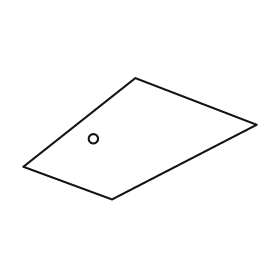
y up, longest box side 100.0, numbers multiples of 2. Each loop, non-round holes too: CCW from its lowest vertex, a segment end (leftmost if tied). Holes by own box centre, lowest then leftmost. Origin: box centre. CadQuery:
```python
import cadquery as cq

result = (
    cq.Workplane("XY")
    .moveTo(-12.0, -26.0)
    .lineTo(50.0, 6.0)
    .lineTo(-2.0, 26.0)
    .lineTo(-50.0, -12.0)
    .close()
    .moveTo(-20.0, 0.0)
    .circle(2.0)
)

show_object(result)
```